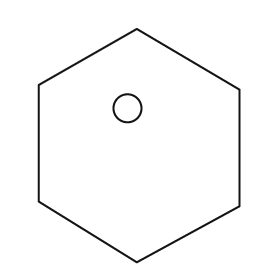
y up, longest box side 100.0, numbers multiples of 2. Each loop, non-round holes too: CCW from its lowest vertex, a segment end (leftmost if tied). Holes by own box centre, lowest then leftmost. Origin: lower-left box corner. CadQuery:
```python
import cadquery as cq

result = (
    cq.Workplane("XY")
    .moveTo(42.0, 0.0)
    .lineTo(86.0, 24.0)
    .lineTo(86.0, 74.0)
    .lineTo(42.0, 100.0)
    .lineTo(0.0, 76.0)
    .lineTo(0.0, 26.0)
    .close()
    .moveTo(38.0, 66.0)
    .circle(6.0)
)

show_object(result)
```